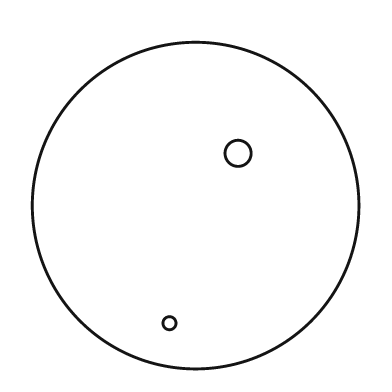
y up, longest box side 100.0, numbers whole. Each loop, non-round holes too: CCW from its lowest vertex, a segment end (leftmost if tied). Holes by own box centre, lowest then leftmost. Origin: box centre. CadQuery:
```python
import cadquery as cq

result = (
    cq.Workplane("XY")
    .moveTo(0.0, 0.0)
    .circle(50.0)
    .moveTo(-8.0, -36.0)
    .circle(2.0)
    .moveTo(13.0, 16.0)
    .circle(4.0)
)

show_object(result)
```